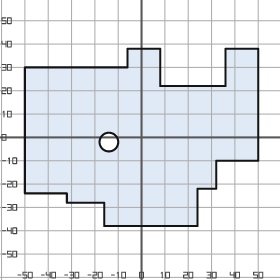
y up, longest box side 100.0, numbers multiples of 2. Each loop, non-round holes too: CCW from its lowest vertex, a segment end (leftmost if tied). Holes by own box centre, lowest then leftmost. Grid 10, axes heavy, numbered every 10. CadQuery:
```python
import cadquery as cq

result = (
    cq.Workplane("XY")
    .moveTo(-16.0, -38.0)
    .lineTo(24.0, -38.0)
    .lineTo(24.0, -22.0)
    .lineTo(32.0, -22.0)
    .lineTo(32.0, -10.0)
    .lineTo(50.0, -10.0)
    .lineTo(50.0, 38.0)
    .lineTo(36.0, 38.0)
    .lineTo(36.0, 22.0)
    .lineTo(8.0, 22.0)
    .lineTo(8.0, 38.0)
    .lineTo(-6.0, 38.0)
    .lineTo(-6.0, 30.0)
    .lineTo(-50.0, 30.0)
    .lineTo(-50.0, -24.0)
    .lineTo(-32.0, -24.0)
    .lineTo(-32.0, -28.0)
    .lineTo(-16.0, -28.0)
    .close()
    .moveTo(-14.0, -2.0)
    .circle(4.0)
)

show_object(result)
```